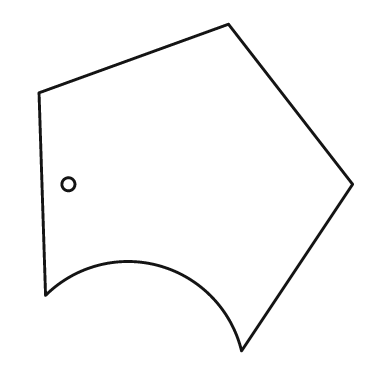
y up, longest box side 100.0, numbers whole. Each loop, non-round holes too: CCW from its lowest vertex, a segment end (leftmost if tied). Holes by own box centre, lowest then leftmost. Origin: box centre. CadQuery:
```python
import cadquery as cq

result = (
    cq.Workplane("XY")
    .moveTo(14.0, -50.0)
    .lineTo(48.0, 1.0)
    .lineTo(10.0, 50.0)
    .lineTo(-48.0, 29.0)
    .lineTo(-46.0, -33.0)
    .threePointArc((-11.0, -24.0), (14.0, -50.0))
    .close()
    .moveTo(-39.0, 1.0)
    .circle(2.0)
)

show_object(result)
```